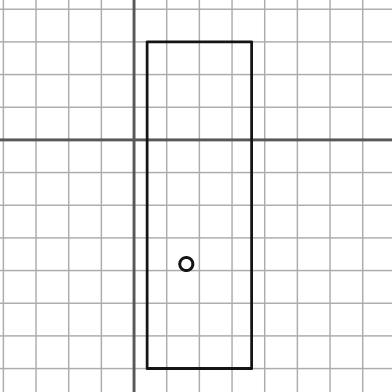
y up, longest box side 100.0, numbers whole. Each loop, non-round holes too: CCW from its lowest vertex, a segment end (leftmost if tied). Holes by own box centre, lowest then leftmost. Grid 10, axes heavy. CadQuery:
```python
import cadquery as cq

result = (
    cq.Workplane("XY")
    .moveTo(4.0, -70.0)
    .lineTo(36.0, -70.0)
    .lineTo(36.0, 30.0)
    .lineTo(4.0, 30.0)
    .close()
    .moveTo(16.0, -38.0)
    .circle(2.0)
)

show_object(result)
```